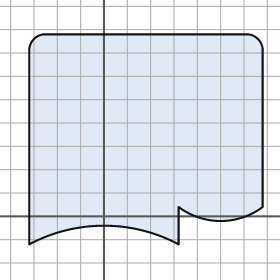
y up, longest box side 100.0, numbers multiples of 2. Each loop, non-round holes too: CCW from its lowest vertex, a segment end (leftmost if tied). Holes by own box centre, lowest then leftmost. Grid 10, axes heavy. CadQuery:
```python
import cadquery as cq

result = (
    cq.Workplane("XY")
    .moveTo(-32.0, -12.0)
    .threePointArc((0.0, -4.0), (32.0, -12.0))
    .lineTo(32.0, 4.0)
    .threePointArc((50.0, -2.0), (68.0, 4.0))
    .lineTo(68.0, 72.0)
    .threePointArc((66.0, 76.0), (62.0, 78.0))
    .lineTo(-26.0, 78.0)
    .threePointArc((-30.0, 76.0), (-32.0, 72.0))
    .close()
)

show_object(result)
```